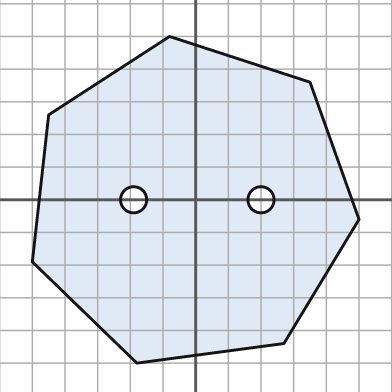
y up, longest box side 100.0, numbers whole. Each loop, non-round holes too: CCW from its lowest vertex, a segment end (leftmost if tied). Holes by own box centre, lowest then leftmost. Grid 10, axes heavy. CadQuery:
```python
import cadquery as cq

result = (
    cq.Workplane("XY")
    .moveTo(-18.0, -50.0)
    .lineTo(27.0, -44.0)
    .lineTo(50.0, -6.0)
    .lineTo(35.0, 36.0)
    .lineTo(-8.0, 50.0)
    .lineTo(-45.0, 26.0)
    .lineTo(-50.0, -19.0)
    .close()
    .moveTo(-19.0, 0.0)
    .circle(4.0)
    .moveTo(20.0, 0.0)
    .circle(4.0)
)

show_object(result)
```